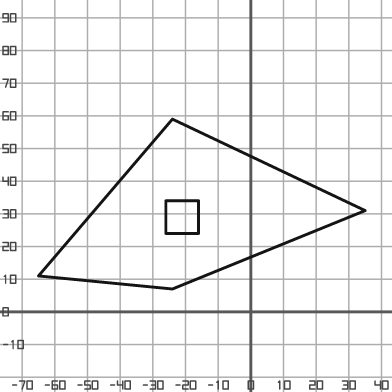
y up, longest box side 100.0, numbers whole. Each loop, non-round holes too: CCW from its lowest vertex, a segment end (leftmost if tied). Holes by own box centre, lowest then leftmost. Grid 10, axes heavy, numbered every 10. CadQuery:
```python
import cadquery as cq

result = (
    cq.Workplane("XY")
    .moveTo(-24.0, 7.0)
    .lineTo(35.0, 31.0)
    .lineTo(-24.0, 59.0)
    .lineTo(-65.0, 11.0)
    .close()
    .moveTo(-26.0, 24.0)
    .lineTo(-16.0, 24.0)
    .lineTo(-16.0, 34.0)
    .lineTo(-26.0, 34.0)
    .close()
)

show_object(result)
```